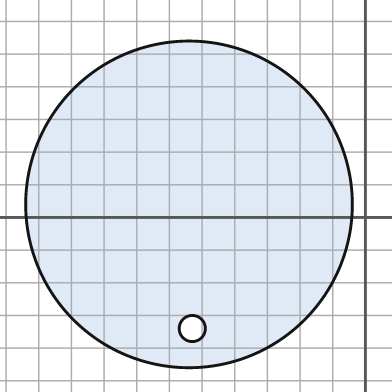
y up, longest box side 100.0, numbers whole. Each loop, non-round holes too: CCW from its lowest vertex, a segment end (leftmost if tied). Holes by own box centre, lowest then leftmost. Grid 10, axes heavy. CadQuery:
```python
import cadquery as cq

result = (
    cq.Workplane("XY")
    .moveTo(-54.0, 4.0)
    .circle(50.0)
    .moveTo(-53.0, -34.0)
    .circle(4.0)
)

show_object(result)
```